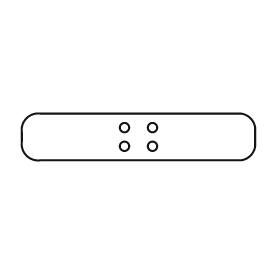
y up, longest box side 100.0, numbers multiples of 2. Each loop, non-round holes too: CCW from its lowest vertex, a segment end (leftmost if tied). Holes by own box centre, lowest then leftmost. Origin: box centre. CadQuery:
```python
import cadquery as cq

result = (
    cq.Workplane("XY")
    .moveTo(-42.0, -10.0)
    .lineTo(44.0, -10.0)
    .threePointArc((48.0, -8.0), (50.0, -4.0))
    .lineTo(50.0, 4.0)
    .threePointArc((48.0, 8.0), (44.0, 10.0))
    .lineTo(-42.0, 10.0)
    .threePointArc((-48.0, 8.0), (-50.0, 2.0))
    .lineTo(-50.0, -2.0)
    .threePointArc((-48.0, -8.0), (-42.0, -10.0))
    .close()
    .moveTo(-6.0, -4.0)
    .circle(2.0)
    .moveTo(6.0, -4.0)
    .circle(2.0)
    .moveTo(-6.0, 4.0)
    .circle(2.0)
    .moveTo(6.0, 4.0)
    .circle(2.0)
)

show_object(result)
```